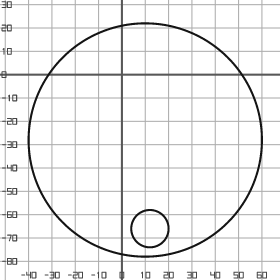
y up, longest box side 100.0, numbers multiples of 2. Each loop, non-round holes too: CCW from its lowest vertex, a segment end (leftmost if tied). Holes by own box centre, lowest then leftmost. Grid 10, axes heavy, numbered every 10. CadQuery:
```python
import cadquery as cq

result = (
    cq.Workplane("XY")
    .moveTo(10.0, -28.0)
    .circle(50.0)
    .moveTo(12.0, -66.0)
    .circle(8.0)
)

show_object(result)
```